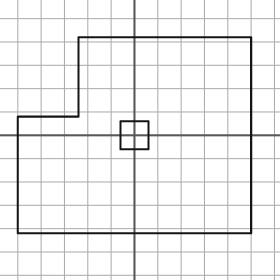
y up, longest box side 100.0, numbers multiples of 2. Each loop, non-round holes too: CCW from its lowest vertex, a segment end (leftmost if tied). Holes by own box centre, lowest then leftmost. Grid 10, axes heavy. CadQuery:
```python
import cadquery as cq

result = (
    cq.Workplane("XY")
    .moveTo(-50.0, -42.0)
    .lineTo(50.0, -42.0)
    .lineTo(50.0, 42.0)
    .lineTo(-24.0, 42.0)
    .lineTo(-24.0, 8.0)
    .lineTo(-50.0, 8.0)
    .close()
    .moveTo(-6.0, -6.0)
    .lineTo(6.0, -6.0)
    .lineTo(6.0, 6.0)
    .lineTo(-6.0, 6.0)
    .close()
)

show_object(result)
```